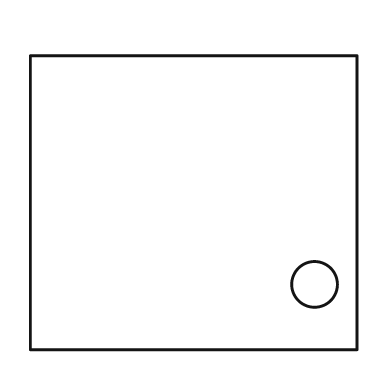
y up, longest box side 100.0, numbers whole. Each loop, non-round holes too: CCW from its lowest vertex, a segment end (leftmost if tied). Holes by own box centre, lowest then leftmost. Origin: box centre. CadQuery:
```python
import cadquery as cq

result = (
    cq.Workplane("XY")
    .moveTo(-50.0, -45.0)
    .lineTo(50.0, -45.0)
    .lineTo(50.0, 45.0)
    .lineTo(-50.0, 45.0)
    .close()
    .moveTo(37.0, -25.0)
    .circle(7.0)
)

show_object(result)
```